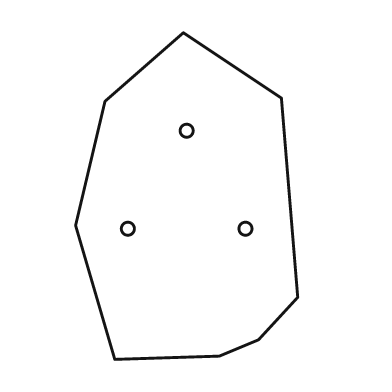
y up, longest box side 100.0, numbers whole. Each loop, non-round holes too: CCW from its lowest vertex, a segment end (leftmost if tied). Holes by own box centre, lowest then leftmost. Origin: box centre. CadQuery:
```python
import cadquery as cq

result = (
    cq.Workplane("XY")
    .moveTo(-22.0, -50.0)
    .lineTo(10.0, -49.0)
    .lineTo(22.0, -44.0)
    .lineTo(34.0, -31.0)
    .lineTo(29.0, 30.0)
    .lineTo(-1.0, 50.0)
    .lineTo(-25.0, 29.0)
    .lineTo(-34.0, -9.0)
    .close()
    .moveTo(-18.0, -10.0)
    .circle(2.0)
    .moveTo(18.0, -10.0)
    .circle(2.0)
    .moveTo(0.0, 20.0)
    .circle(2.0)
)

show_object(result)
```